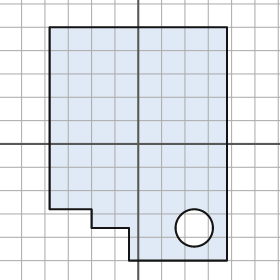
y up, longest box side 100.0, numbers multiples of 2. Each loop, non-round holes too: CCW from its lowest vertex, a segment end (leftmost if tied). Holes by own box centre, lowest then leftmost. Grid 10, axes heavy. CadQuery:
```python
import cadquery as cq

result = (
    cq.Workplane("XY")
    .moveTo(-4.0, -50.0)
    .lineTo(38.0, -50.0)
    .lineTo(38.0, 50.0)
    .lineTo(-38.0, 50.0)
    .lineTo(-38.0, -28.0)
    .lineTo(-20.0, -28.0)
    .lineTo(-20.0, -36.0)
    .lineTo(-4.0, -36.0)
    .close()
    .moveTo(24.0, -36.0)
    .circle(8.0)
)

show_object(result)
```